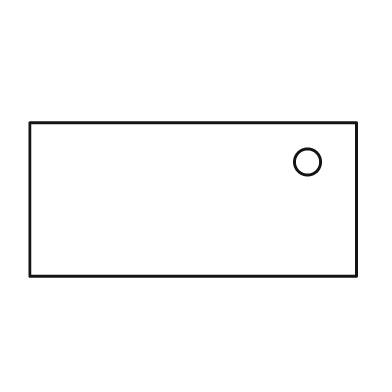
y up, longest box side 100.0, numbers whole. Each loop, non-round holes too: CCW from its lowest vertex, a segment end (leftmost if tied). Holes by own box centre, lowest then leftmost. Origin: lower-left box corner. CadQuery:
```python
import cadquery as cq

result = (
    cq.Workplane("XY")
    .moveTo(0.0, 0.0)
    .lineTo(100.0, 0.0)
    .lineTo(100.0, 47.0)
    .lineTo(0.0, 47.0)
    .close()
    .moveTo(85.0, 35.0)
    .circle(4.0)
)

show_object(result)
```